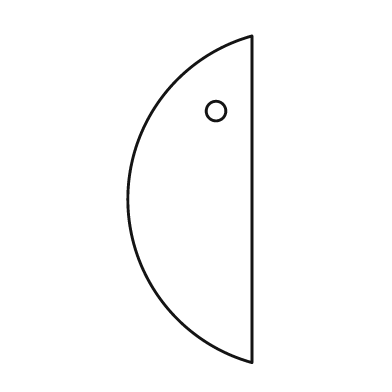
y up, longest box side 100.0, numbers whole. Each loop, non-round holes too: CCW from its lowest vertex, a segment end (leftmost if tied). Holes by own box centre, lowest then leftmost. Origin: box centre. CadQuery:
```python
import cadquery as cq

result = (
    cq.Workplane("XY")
    .moveTo(19.0, -50.0)
    .lineTo(19.0, 50.0)
    .threePointArc((-19.0, 0.0), (19.0, -50.0))
    .close()
    .moveTo(8.0, 27.0)
    .circle(3.0)
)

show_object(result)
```